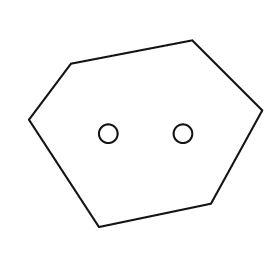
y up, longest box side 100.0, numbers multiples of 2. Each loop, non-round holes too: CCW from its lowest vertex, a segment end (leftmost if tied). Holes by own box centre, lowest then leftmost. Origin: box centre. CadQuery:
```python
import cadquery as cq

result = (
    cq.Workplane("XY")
    .moveTo(-20.0, -40.0)
    .lineTo(28.0, -30.0)
    .lineTo(50.0, 10.0)
    .lineTo(20.0, 40.0)
    .lineTo(-32.0, 30.0)
    .lineTo(-50.0, 6.0)
    .close()
    .moveTo(-16.0, 0.0)
    .circle(4.0)
    .moveTo(16.0, 0.0)
    .circle(4.0)
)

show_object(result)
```